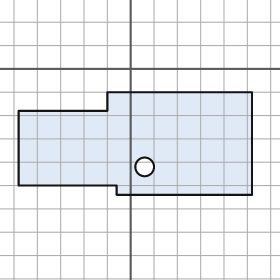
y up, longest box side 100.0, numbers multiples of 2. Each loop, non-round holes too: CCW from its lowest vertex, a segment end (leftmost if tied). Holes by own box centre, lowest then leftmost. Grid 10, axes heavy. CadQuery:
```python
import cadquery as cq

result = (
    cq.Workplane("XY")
    .moveTo(-6.0, -54.0)
    .lineTo(52.0, -54.0)
    .lineTo(52.0, -10.0)
    .lineTo(-10.0, -10.0)
    .lineTo(-10.0, -18.0)
    .lineTo(-48.0, -18.0)
    .lineTo(-48.0, -50.0)
    .lineTo(-6.0, -50.0)
    .close()
    .moveTo(6.0, -42.0)
    .circle(4.0)
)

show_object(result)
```